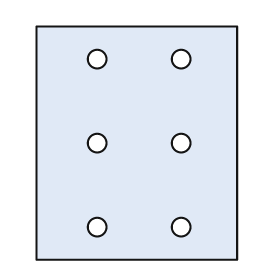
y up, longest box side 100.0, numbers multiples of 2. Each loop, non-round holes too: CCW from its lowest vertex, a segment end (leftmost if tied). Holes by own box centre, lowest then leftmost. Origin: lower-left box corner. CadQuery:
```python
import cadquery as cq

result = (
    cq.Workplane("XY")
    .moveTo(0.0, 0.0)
    .lineTo(86.0, 0.0)
    .lineTo(86.0, 100.0)
    .lineTo(0.0, 100.0)
    .close()
    .moveTo(26.0, 14.0)
    .circle(4.0)
    .moveTo(62.0, 14.0)
    .circle(4.0)
    .moveTo(26.0, 50.0)
    .circle(4.0)
    .moveTo(62.0, 50.0)
    .circle(4.0)
    .moveTo(26.0, 86.0)
    .circle(4.0)
    .moveTo(62.0, 86.0)
    .circle(4.0)
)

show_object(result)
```